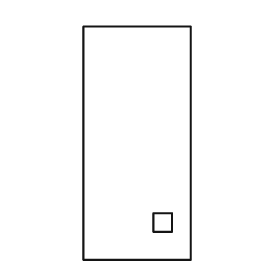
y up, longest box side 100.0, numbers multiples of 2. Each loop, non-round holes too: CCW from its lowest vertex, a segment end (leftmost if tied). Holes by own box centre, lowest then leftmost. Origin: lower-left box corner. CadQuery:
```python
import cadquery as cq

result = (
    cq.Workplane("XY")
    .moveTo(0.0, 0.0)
    .lineTo(46.0, 0.0)
    .lineTo(46.0, 100.0)
    .lineTo(0.0, 100.0)
    .close()
    .moveTo(30.0, 12.0)
    .lineTo(38.0, 12.0)
    .lineTo(38.0, 20.0)
    .lineTo(30.0, 20.0)
    .close()
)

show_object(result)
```